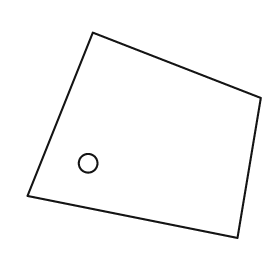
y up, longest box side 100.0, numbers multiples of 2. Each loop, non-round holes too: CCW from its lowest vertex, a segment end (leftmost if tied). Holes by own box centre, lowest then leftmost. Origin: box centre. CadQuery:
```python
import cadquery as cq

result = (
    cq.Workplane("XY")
    .moveTo(40.0, -44.0)
    .lineTo(50.0, 16.0)
    .lineTo(-22.0, 44.0)
    .lineTo(-50.0, -26.0)
    .close()
    .moveTo(-24.0, -12.0)
    .circle(4.0)
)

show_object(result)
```